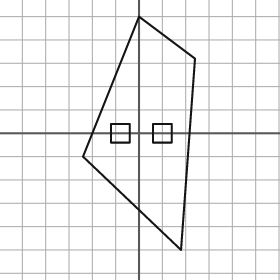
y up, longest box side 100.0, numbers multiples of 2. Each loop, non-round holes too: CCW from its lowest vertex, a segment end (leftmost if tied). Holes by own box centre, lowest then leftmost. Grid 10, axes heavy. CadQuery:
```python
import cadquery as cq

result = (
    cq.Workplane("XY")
    .moveTo(18.0, -50.0)
    .lineTo(24.0, 32.0)
    .lineTo(0.0, 50.0)
    .lineTo(-24.0, -10.0)
    .close()
    .moveTo(-12.0, -4.0)
    .lineTo(-4.0, -4.0)
    .lineTo(-4.0, 4.0)
    .lineTo(-12.0, 4.0)
    .close()
    .moveTo(6.0, -4.0)
    .lineTo(14.0, -4.0)
    .lineTo(14.0, 4.0)
    .lineTo(6.0, 4.0)
    .close()
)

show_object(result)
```